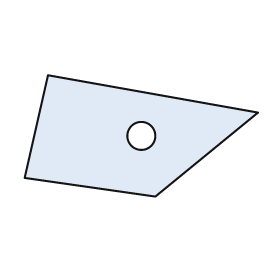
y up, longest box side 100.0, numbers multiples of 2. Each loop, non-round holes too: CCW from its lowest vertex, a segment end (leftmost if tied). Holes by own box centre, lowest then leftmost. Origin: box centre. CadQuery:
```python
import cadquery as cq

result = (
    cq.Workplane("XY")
    .moveTo(6.0, -26.0)
    .lineTo(50.0, 10.0)
    .lineTo(-40.0, 26.0)
    .lineTo(-50.0, -18.0)
    .close()
    .moveTo(0.0, 0.0)
    .circle(6.0)
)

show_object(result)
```